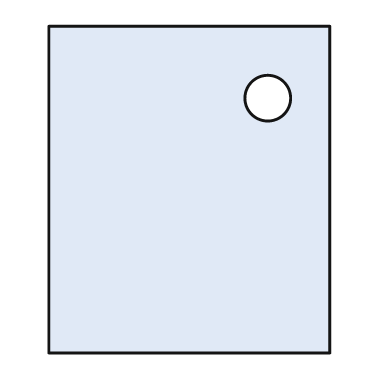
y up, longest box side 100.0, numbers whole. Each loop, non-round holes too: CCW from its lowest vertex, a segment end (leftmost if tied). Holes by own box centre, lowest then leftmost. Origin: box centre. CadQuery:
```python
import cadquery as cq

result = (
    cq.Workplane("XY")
    .moveTo(-43.0, -50.0)
    .lineTo(43.0, -50.0)
    .lineTo(43.0, 50.0)
    .lineTo(-43.0, 50.0)
    .close()
    .moveTo(24.0, 28.0)
    .circle(7.0)
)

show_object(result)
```